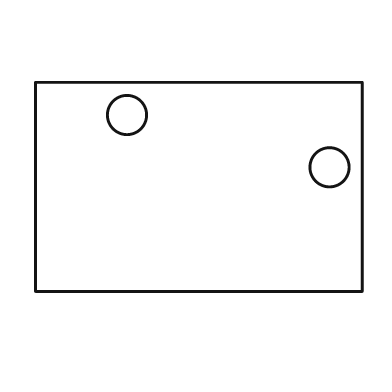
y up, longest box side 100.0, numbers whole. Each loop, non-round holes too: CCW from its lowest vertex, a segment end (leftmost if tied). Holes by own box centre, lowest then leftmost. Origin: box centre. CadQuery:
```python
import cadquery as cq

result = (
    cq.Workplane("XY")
    .moveTo(-50.0, -32.0)
    .lineTo(50.0, -32.0)
    .lineTo(50.0, 32.0)
    .lineTo(-50.0, 32.0)
    .close()
    .moveTo(40.0, 6.0)
    .circle(6.0)
    .moveTo(-22.0, 22.0)
    .circle(6.0)
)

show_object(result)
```